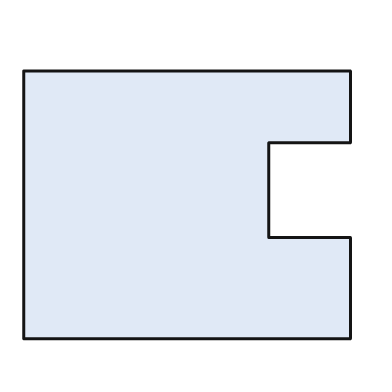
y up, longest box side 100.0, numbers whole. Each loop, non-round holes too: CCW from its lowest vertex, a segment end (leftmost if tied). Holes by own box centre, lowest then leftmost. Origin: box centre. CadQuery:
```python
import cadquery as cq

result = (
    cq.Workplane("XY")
    .moveTo(-50.0, -41.0)
    .lineTo(50.0, -41.0)
    .lineTo(50.0, -10.0)
    .lineTo(25.0, -10.0)
    .lineTo(25.0, 19.0)
    .lineTo(50.0, 19.0)
    .lineTo(50.0, 41.0)
    .lineTo(-50.0, 41.0)
    .close()
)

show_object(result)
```